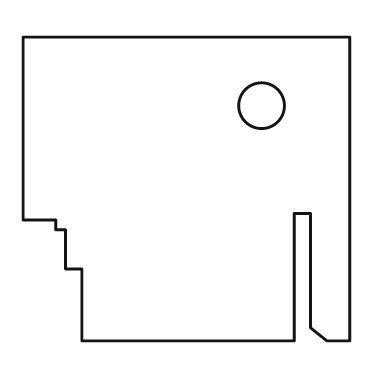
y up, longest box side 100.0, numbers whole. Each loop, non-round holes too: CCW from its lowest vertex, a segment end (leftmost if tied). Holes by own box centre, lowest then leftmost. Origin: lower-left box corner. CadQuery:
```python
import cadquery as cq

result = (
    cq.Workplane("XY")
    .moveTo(18.0, 0.0)
    .lineTo(83.0, 0.0)
    .lineTo(83.0, 39.0)
    .lineTo(88.0, 39.0)
    .lineTo(88.0, 4.0)
    .lineTo(93.0, 0.0)
    .lineTo(100.0, 0.0)
    .lineTo(100.0, 93.0)
    .lineTo(0.0, 93.0)
    .lineTo(0.0, 37.0)
    .lineTo(10.0, 37.0)
    .lineTo(10.0, 34.0)
    .lineTo(13.0, 34.0)
    .lineTo(13.0, 22.0)
    .lineTo(18.0, 22.0)
    .close()
    .moveTo(73.0, 72.0)
    .circle(7.0)
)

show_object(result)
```